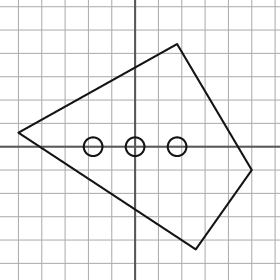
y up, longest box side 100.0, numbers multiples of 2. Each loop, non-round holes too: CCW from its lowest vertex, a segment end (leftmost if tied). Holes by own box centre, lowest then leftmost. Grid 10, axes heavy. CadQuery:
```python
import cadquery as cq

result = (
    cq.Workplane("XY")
    .moveTo(26.0, -44.0)
    .lineTo(50.0, -10.0)
    .lineTo(18.0, 44.0)
    .lineTo(-50.0, 6.0)
    .close()
    .moveTo(-18.0, 0.0)
    .circle(4.0)
    .moveTo(0.0, 0.0)
    .circle(4.0)
    .moveTo(18.0, 0.0)
    .circle(4.0)
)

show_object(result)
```